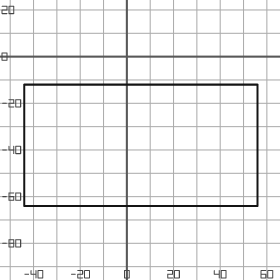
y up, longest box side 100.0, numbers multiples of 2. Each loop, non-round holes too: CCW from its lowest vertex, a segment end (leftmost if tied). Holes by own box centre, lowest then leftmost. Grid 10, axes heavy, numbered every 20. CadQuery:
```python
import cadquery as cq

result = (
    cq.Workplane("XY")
    .moveTo(-44.0, -64.0)
    .lineTo(56.0, -64.0)
    .lineTo(56.0, -12.0)
    .lineTo(-44.0, -12.0)
    .close()
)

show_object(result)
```